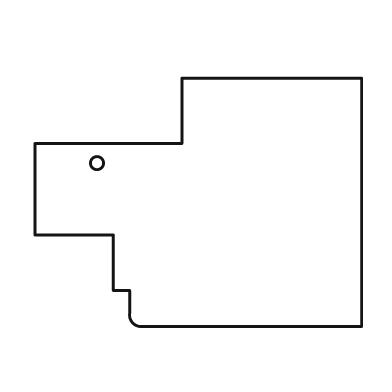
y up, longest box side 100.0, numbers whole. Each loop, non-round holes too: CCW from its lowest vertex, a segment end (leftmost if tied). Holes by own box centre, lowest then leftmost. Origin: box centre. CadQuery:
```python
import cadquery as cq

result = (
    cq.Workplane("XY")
    .moveTo(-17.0, -38.0)
    .lineTo(50.0, -38.0)
    .lineTo(50.0, 38.0)
    .lineTo(-5.0, 38.0)
    .lineTo(-5.0, 18.0)
    .lineTo(-50.0, 18.0)
    .lineTo(-50.0, -10.0)
    .lineTo(-26.0, -10.0)
    .lineTo(-26.0, -27.0)
    .lineTo(-21.0, -27.0)
    .lineTo(-21.0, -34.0)
    .threePointArc((-20.0, -37.0), (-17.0, -38.0))
    .close()
    .moveTo(-31.0, 12.0)
    .circle(2.0)
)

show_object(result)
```